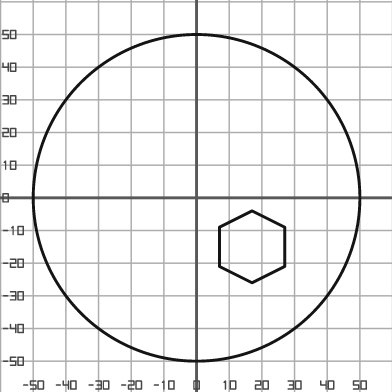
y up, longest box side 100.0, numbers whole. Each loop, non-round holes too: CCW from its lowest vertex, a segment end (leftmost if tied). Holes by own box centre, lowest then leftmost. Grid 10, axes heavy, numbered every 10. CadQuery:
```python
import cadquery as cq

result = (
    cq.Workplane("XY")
    .moveTo(0.0, 0.0)
    .circle(50.0)
    .moveTo(17.0, -26.0)
    .lineTo(27.0, -21.0)
    .lineTo(27.0, -9.0)
    .lineTo(17.0, -4.0)
    .lineTo(7.0, -9.0)
    .lineTo(7.0, -21.0)
    .close()
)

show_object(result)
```